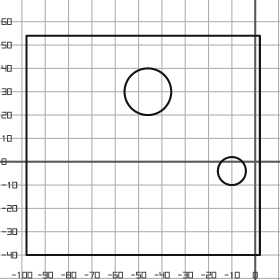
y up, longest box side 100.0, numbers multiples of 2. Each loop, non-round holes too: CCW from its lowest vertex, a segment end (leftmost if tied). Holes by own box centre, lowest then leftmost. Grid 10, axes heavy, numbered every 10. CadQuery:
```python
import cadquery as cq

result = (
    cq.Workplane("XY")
    .moveTo(-98.0, -40.0)
    .lineTo(2.0, -40.0)
    .lineTo(2.0, 54.0)
    .lineTo(-98.0, 54.0)
    .close()
    .moveTo(-10.0, -4.0)
    .circle(6.0)
    .moveTo(-46.0, 30.0)
    .circle(10.0)
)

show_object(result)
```